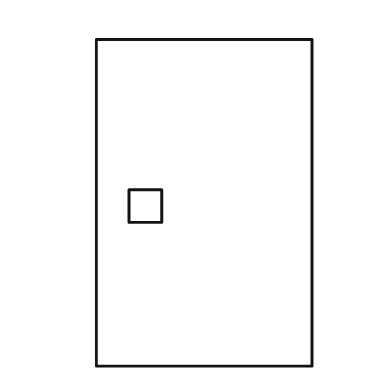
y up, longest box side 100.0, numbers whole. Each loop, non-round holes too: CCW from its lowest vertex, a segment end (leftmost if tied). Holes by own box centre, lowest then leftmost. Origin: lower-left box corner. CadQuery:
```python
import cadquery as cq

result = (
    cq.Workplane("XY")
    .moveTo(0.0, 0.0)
    .lineTo(66.0, 0.0)
    .lineTo(66.0, 100.0)
    .lineTo(0.0, 100.0)
    .close()
    .moveTo(10.0, 44.0)
    .lineTo(20.0, 44.0)
    .lineTo(20.0, 54.0)
    .lineTo(10.0, 54.0)
    .close()
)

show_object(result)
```